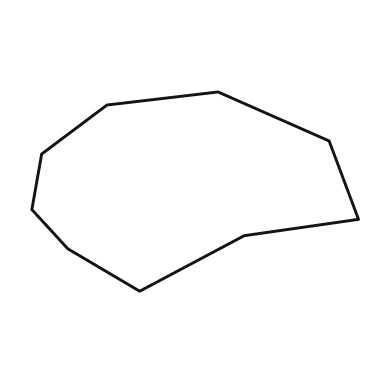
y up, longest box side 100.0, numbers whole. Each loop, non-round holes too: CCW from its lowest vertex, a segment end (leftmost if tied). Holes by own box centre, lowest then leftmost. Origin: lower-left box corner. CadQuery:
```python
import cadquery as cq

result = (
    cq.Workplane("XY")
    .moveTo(33.0, 0.0)
    .lineTo(65.0, 17.0)
    .lineTo(100.0, 22.0)
    .lineTo(91.0, 46.0)
    .lineTo(57.0, 61.0)
    .lineTo(23.0, 57.0)
    .lineTo(3.0, 42.0)
    .lineTo(0.0, 25.0)
    .lineTo(11.0, 13.0)
    .close()
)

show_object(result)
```